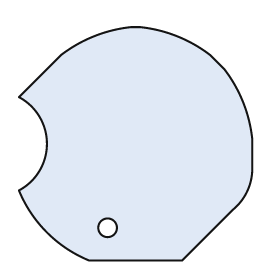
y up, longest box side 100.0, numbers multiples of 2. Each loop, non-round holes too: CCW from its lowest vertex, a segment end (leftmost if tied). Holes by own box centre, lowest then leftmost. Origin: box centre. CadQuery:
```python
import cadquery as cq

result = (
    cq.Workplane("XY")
    .moveTo(-20.0, -50.0)
    .lineTo(20.0, -50.0)
    .lineTo(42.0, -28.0)
    .threePointArc((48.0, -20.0), (50.0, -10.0))
    .lineTo(50.0, 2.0)
    .threePointArc((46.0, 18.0), (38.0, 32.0))
    .lineTo(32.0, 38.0)
    .threePointArc((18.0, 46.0), (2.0, 50.0))
    .lineTo(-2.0, 50.0)
    .threePointArc((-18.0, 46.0), (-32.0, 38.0))
    .lineTo(-50.0, 20.0)
    .threePointArc((-38.0, 0.0), (-50.0, -20.0))
    .threePointArc((-38.0, -38.0), (-20.0, -50.0))
    .close()
    .moveTo(-12.0, -36.0)
    .circle(4.0)
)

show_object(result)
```